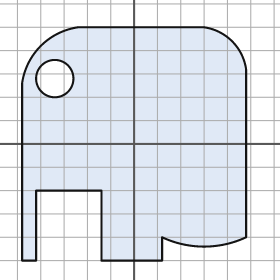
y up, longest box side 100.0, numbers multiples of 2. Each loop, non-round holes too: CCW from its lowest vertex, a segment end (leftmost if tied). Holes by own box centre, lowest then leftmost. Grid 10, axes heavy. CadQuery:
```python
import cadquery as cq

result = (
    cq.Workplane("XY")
    .moveTo(-48.0, -50.0)
    .lineTo(-42.0, -50.0)
    .lineTo(-42.0, -20.0)
    .lineTo(-14.0, -20.0)
    .lineTo(-14.0, -50.0)
    .lineTo(12.0, -50.0)
    .lineTo(12.0, -40.0)
    .threePointArc((30.0, -44.0), (48.0, -40.0))
    .lineTo(48.0, 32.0)
    .threePointArc((42.0, 44.0), (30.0, 50.0))
    .lineTo(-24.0, 50.0)
    .threePointArc((-40.0, 42.0), (-48.0, 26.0))
    .close()
    .moveTo(-34.0, 28.0)
    .circle(8.0)
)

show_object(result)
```